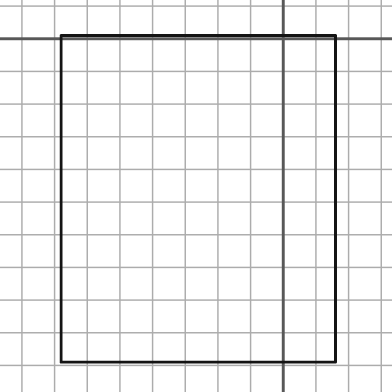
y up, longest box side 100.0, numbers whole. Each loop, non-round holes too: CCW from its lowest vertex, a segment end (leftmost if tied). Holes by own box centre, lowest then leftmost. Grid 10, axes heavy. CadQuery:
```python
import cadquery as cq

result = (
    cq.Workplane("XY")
    .moveTo(-68.0, -99.0)
    .lineTo(16.0, -99.0)
    .lineTo(16.0, 1.0)
    .lineTo(-68.0, 1.0)
    .close()
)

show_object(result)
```